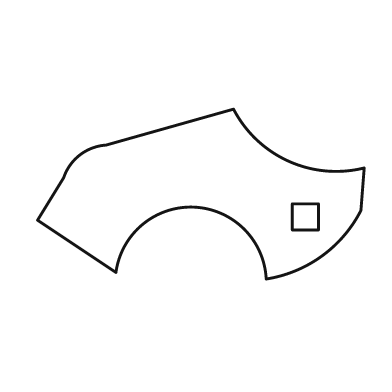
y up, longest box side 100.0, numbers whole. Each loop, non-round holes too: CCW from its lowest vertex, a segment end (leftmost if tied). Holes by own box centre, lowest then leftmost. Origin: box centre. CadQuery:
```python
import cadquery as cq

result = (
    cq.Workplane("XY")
    .moveTo(20.0, -26.0)
    .threePointArc((37.0, -19.0), (49.0, -5.0))
    .lineTo(50.0, 8.0)
    .threePointArc((27.0, 10.0), (10.0, 26.0))
    .lineTo(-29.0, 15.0)
    .threePointArc((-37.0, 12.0), (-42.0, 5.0))
    .lineTo(-50.0, -8.0)
    .lineTo(-26.0, -24.0)
    .threePointArc((-2.0, -4.0), (20.0, -26.0))
    .close()
    .moveTo(28.0, -11.0)
    .lineTo(36.0, -11.0)
    .lineTo(36.0, -3.0)
    .lineTo(28.0, -3.0)
    .close()
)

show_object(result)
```